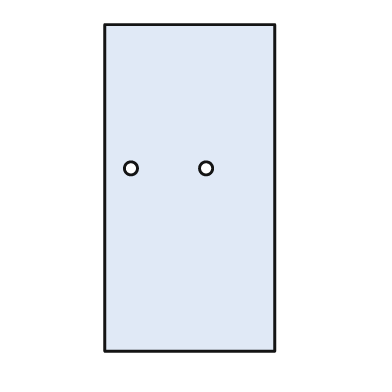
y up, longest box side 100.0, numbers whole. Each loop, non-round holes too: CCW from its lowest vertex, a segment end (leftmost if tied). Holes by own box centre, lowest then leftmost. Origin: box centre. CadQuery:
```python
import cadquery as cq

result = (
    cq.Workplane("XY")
    .moveTo(-26.0, -50.0)
    .lineTo(26.0, -50.0)
    .lineTo(26.0, 50.0)
    .lineTo(-26.0, 50.0)
    .close()
    .moveTo(-18.0, 6.0)
    .circle(2.0)
    .moveTo(5.0, 6.0)
    .circle(2.0)
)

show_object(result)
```